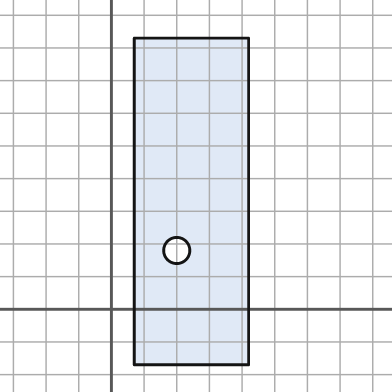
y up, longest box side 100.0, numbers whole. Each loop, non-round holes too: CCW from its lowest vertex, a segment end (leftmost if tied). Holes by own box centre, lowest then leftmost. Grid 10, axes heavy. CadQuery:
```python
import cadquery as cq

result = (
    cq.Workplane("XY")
    .moveTo(7.0, -17.0)
    .lineTo(42.0, -17.0)
    .lineTo(42.0, 83.0)
    .lineTo(7.0, 83.0)
    .close()
    .moveTo(20.0, 18.0)
    .circle(4.0)
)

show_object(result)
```